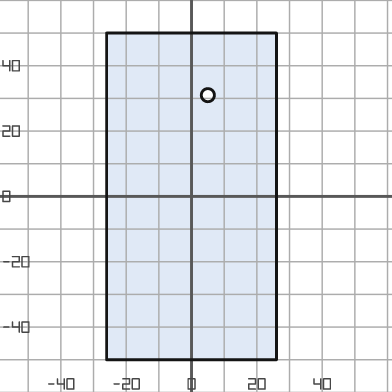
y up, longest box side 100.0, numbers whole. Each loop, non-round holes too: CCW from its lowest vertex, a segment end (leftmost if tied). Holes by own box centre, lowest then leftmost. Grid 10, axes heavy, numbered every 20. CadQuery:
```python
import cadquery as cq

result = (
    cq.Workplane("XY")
    .moveTo(-26.0, -50.0)
    .lineTo(26.0, -50.0)
    .lineTo(26.0, 50.0)
    .lineTo(-26.0, 50.0)
    .close()
    .moveTo(5.0, 31.0)
    .circle(2.0)
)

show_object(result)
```